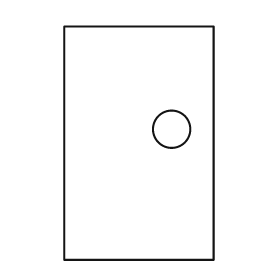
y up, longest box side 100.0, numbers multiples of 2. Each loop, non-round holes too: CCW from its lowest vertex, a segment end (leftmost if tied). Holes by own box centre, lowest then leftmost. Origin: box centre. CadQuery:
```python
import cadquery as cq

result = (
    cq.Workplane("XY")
    .moveTo(-32.0, -50.0)
    .lineTo(32.0, -50.0)
    .lineTo(32.0, 50.0)
    .lineTo(-32.0, 50.0)
    .close()
    .moveTo(14.0, 6.0)
    .circle(8.0)
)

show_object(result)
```